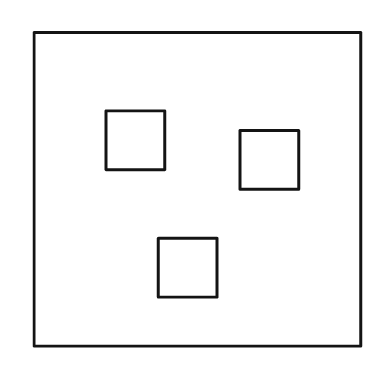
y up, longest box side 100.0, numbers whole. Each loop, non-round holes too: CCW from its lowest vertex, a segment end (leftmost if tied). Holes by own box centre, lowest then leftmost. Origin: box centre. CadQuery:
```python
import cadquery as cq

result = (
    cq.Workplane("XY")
    .moveTo(-50.0, -48.0)
    .lineTo(50.0, -48.0)
    .lineTo(50.0, 48.0)
    .lineTo(-50.0, 48.0)
    .close()
    .moveTo(-12.0, -33.0)
    .lineTo(6.0, -33.0)
    .lineTo(6.0, -15.0)
    .lineTo(-12.0, -15.0)
    .close()
    .moveTo(13.0, 0.0)
    .lineTo(31.0, 0.0)
    .lineTo(31.0, 18.0)
    .lineTo(13.0, 18.0)
    .close()
    .moveTo(-28.0, 6.0)
    .lineTo(-10.0, 6.0)
    .lineTo(-10.0, 24.0)
    .lineTo(-28.0, 24.0)
    .close()
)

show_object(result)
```